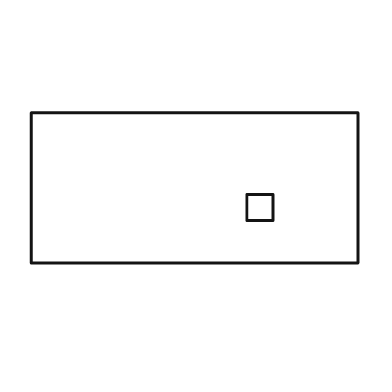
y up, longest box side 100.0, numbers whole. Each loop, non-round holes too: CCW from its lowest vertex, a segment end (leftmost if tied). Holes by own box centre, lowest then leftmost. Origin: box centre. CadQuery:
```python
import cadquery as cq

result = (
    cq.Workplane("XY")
    .moveTo(-50.0, -23.0)
    .lineTo(50.0, -23.0)
    .lineTo(50.0, 23.0)
    .lineTo(-50.0, 23.0)
    .close()
    .moveTo(16.0, -10.0)
    .lineTo(24.0, -10.0)
    .lineTo(24.0, -2.0)
    .lineTo(16.0, -2.0)
    .close()
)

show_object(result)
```